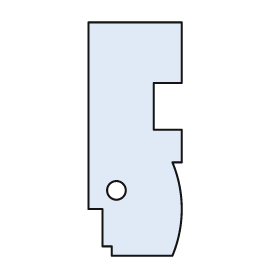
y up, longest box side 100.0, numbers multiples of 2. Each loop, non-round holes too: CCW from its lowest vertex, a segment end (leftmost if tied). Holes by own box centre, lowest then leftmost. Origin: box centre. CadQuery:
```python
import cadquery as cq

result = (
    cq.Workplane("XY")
    .moveTo(-10.0, -50.0)
    .lineTo(16.0, -50.0)
    .threePointArc((20.0, -30.0), (16.0, -10.0))
    .lineTo(20.0, -10.0)
    .lineTo(20.0, 4.0)
    .lineTo(8.0, 4.0)
    .lineTo(8.0, 24.0)
    .lineTo(20.0, 24.0)
    .lineTo(20.0, 50.0)
    .lineTo(-20.0, 50.0)
    .lineTo(-20.0, -30.0)
    .lineTo(-14.0, -30.0)
    .lineTo(-14.0, -46.0)
    .lineTo(-10.0, -46.0)
    .close()
    .moveTo(-8.0, -22.0)
    .circle(4.0)
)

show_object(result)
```